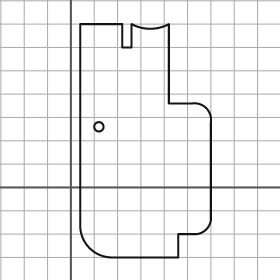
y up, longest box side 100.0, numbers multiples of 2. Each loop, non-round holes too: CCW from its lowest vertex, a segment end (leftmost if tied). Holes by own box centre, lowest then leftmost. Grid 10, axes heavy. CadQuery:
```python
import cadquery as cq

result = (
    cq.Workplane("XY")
    .moveTo(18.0, -30.0)
    .lineTo(46.0, -30.0)
    .lineTo(46.0, -20.0)
    .lineTo(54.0, -20.0)
    .threePointArc((58.0, -18.0), (60.0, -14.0))
    .lineTo(60.0, 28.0)
    .threePointArc((58.0, 34.0), (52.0, 36.0))
    .lineTo(42.0, 36.0)
    .lineTo(42.0, 70.0)
    .threePointArc((34.0, 68.0), (26.0, 70.0))
    .lineTo(26.0, 60.0)
    .lineTo(22.0, 60.0)
    .lineTo(22.0, 70.0)
    .lineTo(4.0, 70.0)
    .lineTo(4.0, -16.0)
    .threePointArc((8.0, -26.0), (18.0, -30.0))
    .close()
    .moveTo(12.0, 26.0)
    .circle(2.0)
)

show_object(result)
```